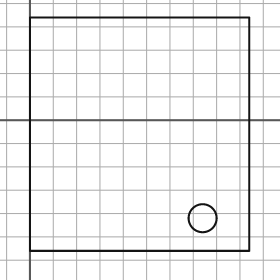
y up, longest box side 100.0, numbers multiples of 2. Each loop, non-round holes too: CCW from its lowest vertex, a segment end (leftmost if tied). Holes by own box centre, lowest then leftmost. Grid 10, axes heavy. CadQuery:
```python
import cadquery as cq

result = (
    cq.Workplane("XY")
    .moveTo(0.0, -56.0)
    .lineTo(94.0, -56.0)
    .lineTo(94.0, 44.0)
    .lineTo(0.0, 44.0)
    .close()
    .moveTo(74.0, -42.0)
    .circle(6.0)
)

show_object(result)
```